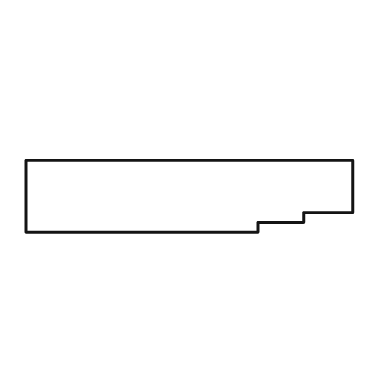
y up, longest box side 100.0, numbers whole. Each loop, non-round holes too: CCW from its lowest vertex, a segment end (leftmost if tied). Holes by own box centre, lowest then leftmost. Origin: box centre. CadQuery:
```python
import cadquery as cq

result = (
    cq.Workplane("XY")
    .moveTo(-50.0, -11.0)
    .lineTo(21.0, -11.0)
    .lineTo(21.0, -8.0)
    .lineTo(35.0, -8.0)
    .lineTo(35.0, -5.0)
    .lineTo(50.0, -5.0)
    .lineTo(50.0, 11.0)
    .lineTo(-50.0, 11.0)
    .close()
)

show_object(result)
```